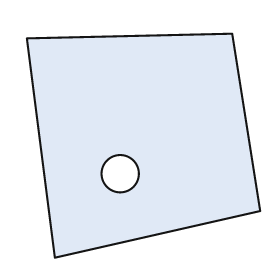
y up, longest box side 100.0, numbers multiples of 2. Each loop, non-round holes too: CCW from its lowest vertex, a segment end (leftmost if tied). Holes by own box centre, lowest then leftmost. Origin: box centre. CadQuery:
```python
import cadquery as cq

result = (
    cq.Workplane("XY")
    .moveTo(-38.0, -48.0)
    .lineTo(50.0, -28.0)
    .lineTo(38.0, 48.0)
    .lineTo(-50.0, 46.0)
    .close()
    .moveTo(-10.0, -12.0)
    .circle(8.0)
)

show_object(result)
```